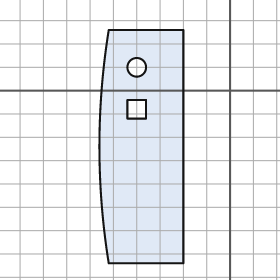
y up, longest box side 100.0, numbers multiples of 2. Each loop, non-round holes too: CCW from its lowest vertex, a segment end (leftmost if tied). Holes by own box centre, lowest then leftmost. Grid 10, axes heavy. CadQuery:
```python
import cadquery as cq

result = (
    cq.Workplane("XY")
    .moveTo(-52.0, -74.0)
    .lineTo(-20.0, -74.0)
    .lineTo(-20.0, 26.0)
    .lineTo(-52.0, 26.0)
    .threePointArc((-56.0, -24.0), (-52.0, -74.0))
    .close()
    .moveTo(-44.0, -12.0)
    .lineTo(-36.0, -12.0)
    .lineTo(-36.0, -4.0)
    .lineTo(-44.0, -4.0)
    .close()
    .moveTo(-40.0, 10.0)
    .circle(4.0)
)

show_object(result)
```